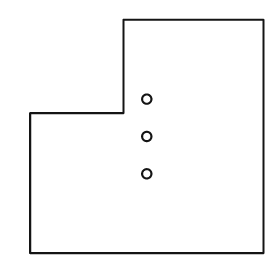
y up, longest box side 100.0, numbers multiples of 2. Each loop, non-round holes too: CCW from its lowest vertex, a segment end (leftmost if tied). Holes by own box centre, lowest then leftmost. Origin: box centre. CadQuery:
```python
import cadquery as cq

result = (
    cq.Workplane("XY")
    .moveTo(-50.0, -50.0)
    .lineTo(50.0, -50.0)
    .lineTo(50.0, 50.0)
    .lineTo(-10.0, 50.0)
    .lineTo(-10.0, 10.0)
    .lineTo(-50.0, 10.0)
    .close()
    .moveTo(0.0, -16.0)
    .circle(2.0)
    .moveTo(0.0, 0.0)
    .circle(2.0)
    .moveTo(0.0, 16.0)
    .circle(2.0)
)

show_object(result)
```